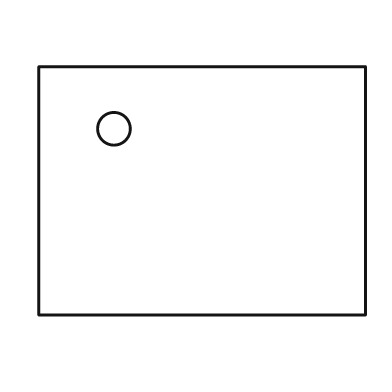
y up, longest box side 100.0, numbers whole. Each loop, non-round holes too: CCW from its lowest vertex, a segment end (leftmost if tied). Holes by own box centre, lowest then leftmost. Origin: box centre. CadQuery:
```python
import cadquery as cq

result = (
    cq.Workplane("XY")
    .moveTo(-50.0, -38.0)
    .lineTo(50.0, -38.0)
    .lineTo(50.0, 38.0)
    .lineTo(-50.0, 38.0)
    .close()
    .moveTo(-27.0, 19.0)
    .circle(5.0)
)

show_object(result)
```